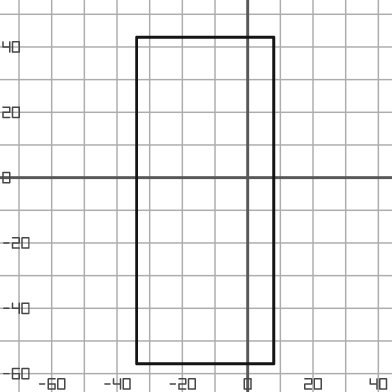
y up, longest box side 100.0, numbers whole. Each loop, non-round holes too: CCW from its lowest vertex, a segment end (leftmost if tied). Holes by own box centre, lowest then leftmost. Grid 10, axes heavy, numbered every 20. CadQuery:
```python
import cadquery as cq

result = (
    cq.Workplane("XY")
    .moveTo(-34.0, -57.0)
    .lineTo(8.0, -57.0)
    .lineTo(8.0, 43.0)
    .lineTo(-34.0, 43.0)
    .close()
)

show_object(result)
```